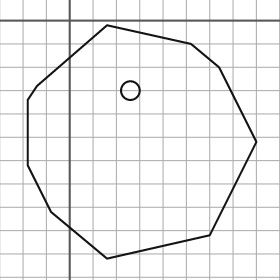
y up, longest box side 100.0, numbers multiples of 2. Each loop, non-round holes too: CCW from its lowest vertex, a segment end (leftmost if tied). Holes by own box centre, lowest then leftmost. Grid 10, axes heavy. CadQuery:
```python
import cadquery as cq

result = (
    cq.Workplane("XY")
    .moveTo(16.0, -102.0)
    .lineTo(60.0, -92.0)
    .lineTo(80.0, -52.0)
    .lineTo(64.0, -20.0)
    .lineTo(52.0, -10.0)
    .lineTo(16.0, -2.0)
    .lineTo(-14.0, -28.0)
    .lineTo(-18.0, -34.0)
    .lineTo(-18.0, -62.0)
    .lineTo(-8.0, -82.0)
    .close()
    .moveTo(26.0, -30.0)
    .circle(4.0)
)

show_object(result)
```